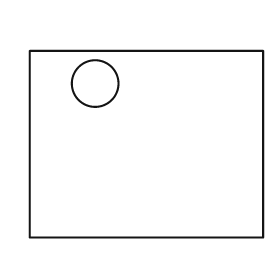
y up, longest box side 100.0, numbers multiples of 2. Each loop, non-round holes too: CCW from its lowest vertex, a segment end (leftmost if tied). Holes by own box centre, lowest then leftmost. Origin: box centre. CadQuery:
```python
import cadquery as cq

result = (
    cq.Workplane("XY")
    .moveTo(-50.0, -40.0)
    .lineTo(50.0, -40.0)
    .lineTo(50.0, 40.0)
    .lineTo(-50.0, 40.0)
    .close()
    .moveTo(-22.0, 26.0)
    .circle(10.0)
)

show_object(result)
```